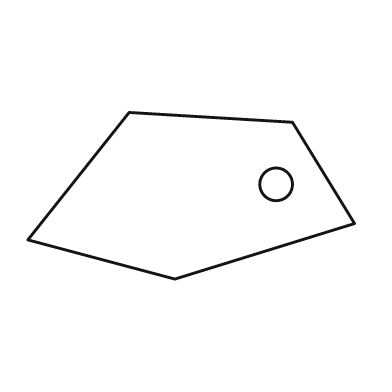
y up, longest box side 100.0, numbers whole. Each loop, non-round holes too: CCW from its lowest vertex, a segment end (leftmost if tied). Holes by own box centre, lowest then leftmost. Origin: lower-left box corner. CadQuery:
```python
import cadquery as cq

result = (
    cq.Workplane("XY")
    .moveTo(45.0, 0.0)
    .lineTo(100.0, 17.0)
    .lineTo(81.0, 48.0)
    .lineTo(31.0, 51.0)
    .lineTo(0.0, 12.0)
    .close()
    .moveTo(76.0, 29.0)
    .circle(5.0)
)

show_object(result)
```